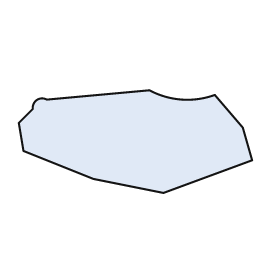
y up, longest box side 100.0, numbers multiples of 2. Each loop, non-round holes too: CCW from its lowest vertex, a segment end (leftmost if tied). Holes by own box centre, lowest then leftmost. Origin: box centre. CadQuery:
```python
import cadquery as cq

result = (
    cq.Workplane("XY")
    .moveTo(12.0, -22.0)
    .lineTo(50.0, -8.0)
    .lineTo(46.0, 6.0)
    .lineTo(34.0, 20.0)
    .threePointArc((20.0, 18.0), (6.0, 22.0))
    .lineTo(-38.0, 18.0)
    .threePointArc((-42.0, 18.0), (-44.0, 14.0))
    .lineTo(-50.0, 8.0)
    .lineTo(-48.0, -4.0)
    .lineTo(-18.0, -16.0)
    .close()
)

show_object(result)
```